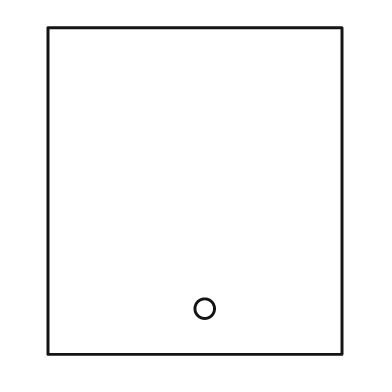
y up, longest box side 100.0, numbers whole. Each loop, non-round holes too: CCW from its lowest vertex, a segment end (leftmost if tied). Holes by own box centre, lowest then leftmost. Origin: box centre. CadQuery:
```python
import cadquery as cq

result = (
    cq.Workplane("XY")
    .moveTo(-45.0, -50.0)
    .lineTo(45.0, -50.0)
    .lineTo(45.0, 50.0)
    .lineTo(-45.0, 50.0)
    .close()
    .moveTo(3.0, -36.0)
    .circle(3.0)
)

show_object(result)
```